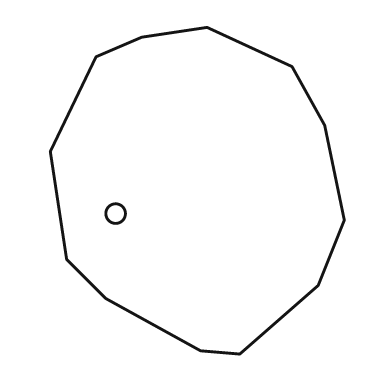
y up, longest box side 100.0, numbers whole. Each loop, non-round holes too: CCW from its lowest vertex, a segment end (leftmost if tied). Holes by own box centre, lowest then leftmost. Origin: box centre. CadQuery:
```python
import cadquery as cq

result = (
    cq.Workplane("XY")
    .moveTo(13.0, -50.0)
    .lineTo(37.0, -29.0)
    .lineTo(45.0, -9.0)
    .lineTo(39.0, 20.0)
    .lineTo(29.0, 38.0)
    .lineTo(3.0, 50.0)
    .lineTo(-17.0, 47.0)
    .lineTo(-31.0, 41.0)
    .lineTo(-45.0, 12.0)
    .lineTo(-40.0, -21.0)
    .lineTo(-28.0, -33.0)
    .lineTo(1.0, -49.0)
    .close()
    .moveTo(-25.0, -7.0)
    .circle(3.0)
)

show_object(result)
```